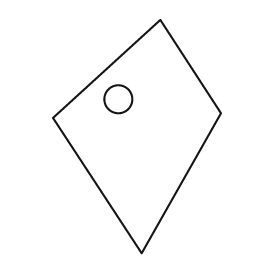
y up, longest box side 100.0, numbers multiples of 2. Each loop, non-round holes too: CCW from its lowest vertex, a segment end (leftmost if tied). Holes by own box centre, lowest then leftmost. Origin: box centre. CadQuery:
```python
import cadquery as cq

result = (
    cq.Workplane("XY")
    .moveTo(2.0, -50.0)
    .lineTo(36.0, 10.0)
    .lineTo(10.0, 50.0)
    .lineTo(-36.0, 8.0)
    .close()
    .moveTo(-8.0, 16.0)
    .circle(6.0)
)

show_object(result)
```